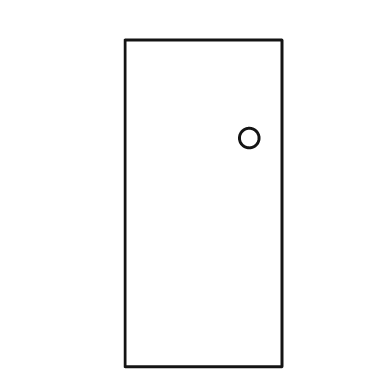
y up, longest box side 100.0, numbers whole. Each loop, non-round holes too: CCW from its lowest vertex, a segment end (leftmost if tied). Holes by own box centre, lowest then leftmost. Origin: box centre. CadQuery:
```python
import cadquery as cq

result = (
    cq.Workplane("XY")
    .moveTo(-24.0, -50.0)
    .lineTo(24.0, -50.0)
    .lineTo(24.0, 50.0)
    .lineTo(-24.0, 50.0)
    .close()
    .moveTo(14.0, 20.0)
    .circle(3.0)
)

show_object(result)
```